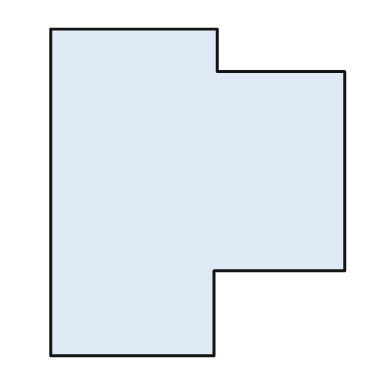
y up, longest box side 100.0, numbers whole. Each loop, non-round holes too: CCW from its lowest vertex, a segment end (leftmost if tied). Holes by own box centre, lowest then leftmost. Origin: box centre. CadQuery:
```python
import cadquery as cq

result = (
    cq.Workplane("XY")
    .moveTo(-45.0, -50.0)
    .lineTo(5.0, -50.0)
    .lineTo(5.0, -24.0)
    .lineTo(45.0, -24.0)
    .lineTo(45.0, 37.0)
    .lineTo(6.0, 37.0)
    .lineTo(6.0, 50.0)
    .lineTo(-45.0, 50.0)
    .close()
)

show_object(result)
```